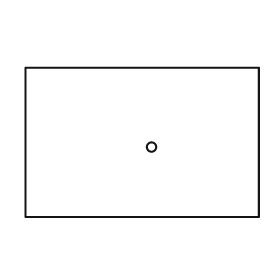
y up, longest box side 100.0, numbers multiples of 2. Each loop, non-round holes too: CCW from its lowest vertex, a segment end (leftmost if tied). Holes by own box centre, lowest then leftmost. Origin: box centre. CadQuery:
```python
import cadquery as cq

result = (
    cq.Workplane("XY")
    .moveTo(-50.0, -32.0)
    .lineTo(50.0, -32.0)
    .lineTo(50.0, 32.0)
    .lineTo(-50.0, 32.0)
    .close()
    .moveTo(4.0, -2.0)
    .circle(2.0)
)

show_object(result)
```